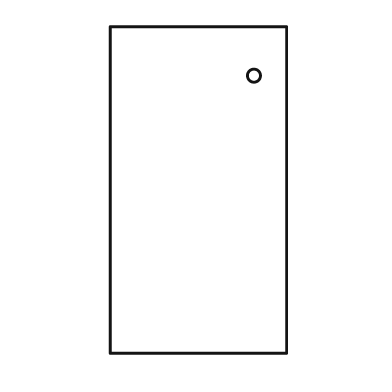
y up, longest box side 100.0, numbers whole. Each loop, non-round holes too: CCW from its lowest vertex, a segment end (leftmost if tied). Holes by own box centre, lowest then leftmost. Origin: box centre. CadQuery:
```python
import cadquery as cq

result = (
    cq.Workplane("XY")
    .moveTo(-27.0, -50.0)
    .lineTo(27.0, -50.0)
    .lineTo(27.0, 50.0)
    .lineTo(-27.0, 50.0)
    .close()
    .moveTo(17.0, 35.0)
    .circle(2.0)
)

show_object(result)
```